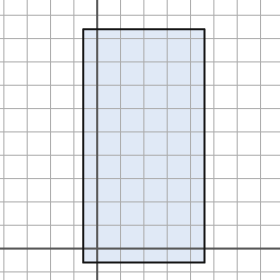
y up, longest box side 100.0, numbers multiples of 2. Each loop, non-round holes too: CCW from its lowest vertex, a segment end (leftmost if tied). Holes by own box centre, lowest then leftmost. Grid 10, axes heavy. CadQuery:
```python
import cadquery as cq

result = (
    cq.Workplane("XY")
    .moveTo(-6.0, -6.0)
    .lineTo(46.0, -6.0)
    .lineTo(46.0, 94.0)
    .lineTo(-6.0, 94.0)
    .close()
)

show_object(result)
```